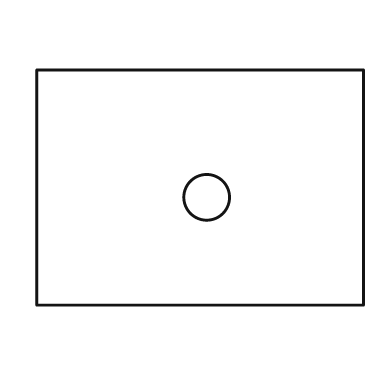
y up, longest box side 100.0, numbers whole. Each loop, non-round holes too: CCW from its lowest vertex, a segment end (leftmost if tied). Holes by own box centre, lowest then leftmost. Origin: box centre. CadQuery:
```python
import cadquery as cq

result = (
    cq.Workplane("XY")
    .moveTo(-50.0, -36.0)
    .lineTo(50.0, -36.0)
    .lineTo(50.0, 36.0)
    .lineTo(-50.0, 36.0)
    .close()
    .moveTo(2.0, -3.0)
    .circle(7.0)
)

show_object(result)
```